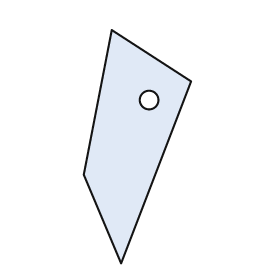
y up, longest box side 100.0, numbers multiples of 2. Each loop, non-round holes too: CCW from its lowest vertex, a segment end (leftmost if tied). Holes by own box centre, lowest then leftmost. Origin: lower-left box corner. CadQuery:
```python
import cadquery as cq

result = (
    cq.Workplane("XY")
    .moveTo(16.0, 0.0)
    .lineTo(46.0, 78.0)
    .lineTo(12.0, 100.0)
    .lineTo(0.0, 38.0)
    .close()
    .moveTo(28.0, 70.0)
    .circle(4.0)
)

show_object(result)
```